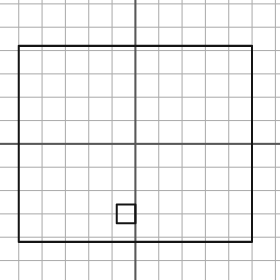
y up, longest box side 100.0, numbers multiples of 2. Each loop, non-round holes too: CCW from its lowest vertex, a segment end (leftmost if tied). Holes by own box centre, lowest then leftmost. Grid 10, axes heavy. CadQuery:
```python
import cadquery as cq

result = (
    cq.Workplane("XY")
    .moveTo(-50.0, -42.0)
    .lineTo(50.0, -42.0)
    .lineTo(50.0, 42.0)
    .lineTo(-50.0, 42.0)
    .close()
    .moveTo(-8.0, -34.0)
    .lineTo(0.0, -34.0)
    .lineTo(0.0, -26.0)
    .lineTo(-8.0, -26.0)
    .close()
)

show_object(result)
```